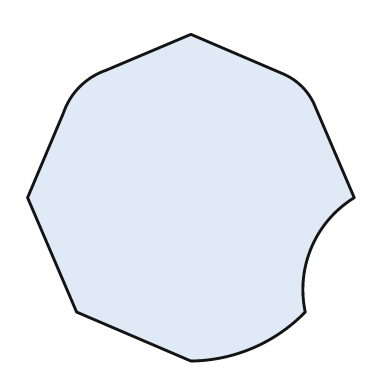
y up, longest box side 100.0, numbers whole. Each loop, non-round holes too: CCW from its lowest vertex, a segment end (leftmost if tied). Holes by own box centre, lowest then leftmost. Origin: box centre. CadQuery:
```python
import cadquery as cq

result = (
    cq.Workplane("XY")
    .moveTo(0.0, -50.0)
    .threePointArc((19.0, -46.0), (35.0, -35.0))
    .threePointArc((37.0, -15.0), (50.0, 0.0))
    .lineTo(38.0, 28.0)
    .threePointArc((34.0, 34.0), (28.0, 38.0))
    .lineTo(0.0, 50.0)
    .lineTo(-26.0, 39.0)
    .threePointArc((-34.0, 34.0), (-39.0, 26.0))
    .lineTo(-50.0, 0.0)
    .lineTo(-35.0, -35.0)
    .close()
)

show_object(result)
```